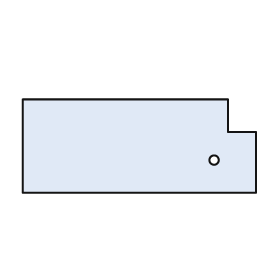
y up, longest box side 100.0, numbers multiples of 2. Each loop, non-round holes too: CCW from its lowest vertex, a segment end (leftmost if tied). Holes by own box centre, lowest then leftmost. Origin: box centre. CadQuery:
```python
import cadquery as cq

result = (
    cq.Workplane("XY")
    .moveTo(-50.0, -20.0)
    .lineTo(50.0, -20.0)
    .lineTo(50.0, 6.0)
    .lineTo(38.0, 6.0)
    .lineTo(38.0, 20.0)
    .lineTo(-50.0, 20.0)
    .close()
    .moveTo(32.0, -6.0)
    .circle(2.0)
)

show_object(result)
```